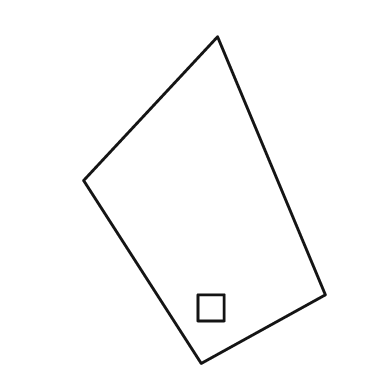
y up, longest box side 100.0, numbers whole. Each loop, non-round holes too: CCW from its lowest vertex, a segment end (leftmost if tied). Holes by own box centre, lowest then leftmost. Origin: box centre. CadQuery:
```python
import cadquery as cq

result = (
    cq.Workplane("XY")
    .moveTo(-1.0, -50.0)
    .lineTo(37.0, -29.0)
    .lineTo(4.0, 50.0)
    .lineTo(-37.0, 6.0)
    .close()
    .moveTo(-2.0, -37.0)
    .lineTo(6.0, -37.0)
    .lineTo(6.0, -29.0)
    .lineTo(-2.0, -29.0)
    .close()
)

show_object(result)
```